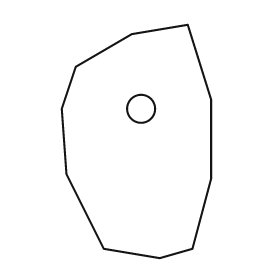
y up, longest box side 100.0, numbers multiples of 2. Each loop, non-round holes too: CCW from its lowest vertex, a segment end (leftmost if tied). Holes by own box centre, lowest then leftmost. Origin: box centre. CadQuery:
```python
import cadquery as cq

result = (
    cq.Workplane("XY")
    .moveTo(10.0, -50.0)
    .lineTo(24.0, -46.0)
    .lineTo(32.0, -16.0)
    .lineTo(32.0, 18.0)
    .lineTo(22.0, 50.0)
    .lineTo(-2.0, 46.0)
    .lineTo(-26.0, 32.0)
    .lineTo(-32.0, 14.0)
    .lineTo(-30.0, -14.0)
    .lineTo(-14.0, -46.0)
    .close()
    .moveTo(2.0, 14.0)
    .circle(6.0)
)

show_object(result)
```